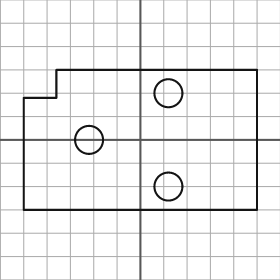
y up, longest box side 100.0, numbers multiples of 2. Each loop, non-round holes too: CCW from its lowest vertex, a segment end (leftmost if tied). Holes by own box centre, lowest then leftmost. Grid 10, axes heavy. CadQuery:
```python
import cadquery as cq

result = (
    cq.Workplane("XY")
    .moveTo(-50.0, -30.0)
    .lineTo(50.0, -30.0)
    .lineTo(50.0, 30.0)
    .lineTo(-36.0, 30.0)
    .lineTo(-36.0, 18.0)
    .lineTo(-50.0, 18.0)
    .close()
    .moveTo(12.0, -20.0)
    .circle(6.0)
    .moveTo(-22.0, 0.0)
    .circle(6.0)
    .moveTo(12.0, 20.0)
    .circle(6.0)
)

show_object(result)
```